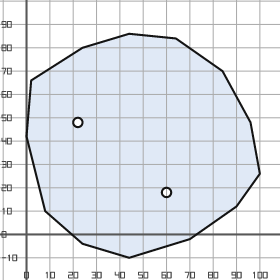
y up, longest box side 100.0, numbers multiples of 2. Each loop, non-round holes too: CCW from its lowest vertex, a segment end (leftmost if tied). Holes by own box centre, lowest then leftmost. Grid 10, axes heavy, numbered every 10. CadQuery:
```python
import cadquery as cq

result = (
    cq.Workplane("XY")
    .moveTo(44.0, -10.0)
    .lineTo(70.0, -2.0)
    .lineTo(90.0, 12.0)
    .lineTo(100.0, 26.0)
    .lineTo(96.0, 48.0)
    .lineTo(84.0, 70.0)
    .lineTo(64.0, 84.0)
    .lineTo(44.0, 86.0)
    .lineTo(24.0, 80.0)
    .lineTo(2.0, 66.0)
    .lineTo(0.0, 42.0)
    .lineTo(8.0, 10.0)
    .lineTo(24.0, -4.0)
    .close()
    .moveTo(60.0, 18.0)
    .circle(2.0)
    .moveTo(22.0, 48.0)
    .circle(2.0)
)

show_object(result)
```